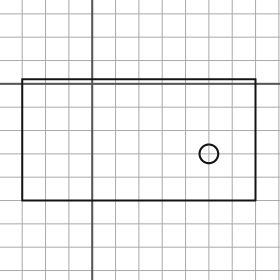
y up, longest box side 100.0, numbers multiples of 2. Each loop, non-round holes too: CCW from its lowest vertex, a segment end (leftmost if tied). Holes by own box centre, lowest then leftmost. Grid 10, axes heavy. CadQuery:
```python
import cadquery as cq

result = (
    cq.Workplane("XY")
    .moveTo(-30.0, -50.0)
    .lineTo(70.0, -50.0)
    .lineTo(70.0, 2.0)
    .lineTo(-30.0, 2.0)
    .close()
    .moveTo(50.0, -30.0)
    .circle(4.0)
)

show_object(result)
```